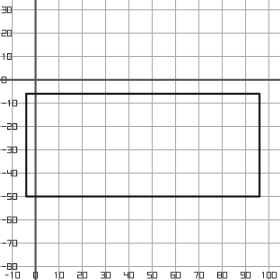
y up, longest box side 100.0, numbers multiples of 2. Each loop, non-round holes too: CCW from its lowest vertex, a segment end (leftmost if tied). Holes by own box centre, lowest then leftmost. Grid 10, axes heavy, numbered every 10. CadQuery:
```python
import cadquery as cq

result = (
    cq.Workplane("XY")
    .moveTo(-4.0, -50.0)
    .lineTo(96.0, -50.0)
    .lineTo(96.0, -6.0)
    .lineTo(-4.0, -6.0)
    .close()
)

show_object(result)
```